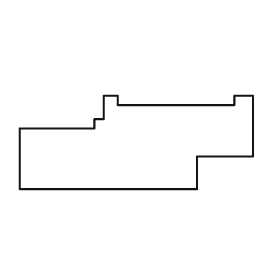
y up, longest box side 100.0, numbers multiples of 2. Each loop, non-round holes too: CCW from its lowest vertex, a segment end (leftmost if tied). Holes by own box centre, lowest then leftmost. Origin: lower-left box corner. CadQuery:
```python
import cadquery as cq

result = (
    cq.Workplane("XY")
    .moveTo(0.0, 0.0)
    .lineTo(76.0, 0.0)
    .lineTo(76.0, 14.0)
    .lineTo(100.0, 14.0)
    .lineTo(100.0, 40.0)
    .lineTo(92.0, 40.0)
    .lineTo(92.0, 36.0)
    .lineTo(42.0, 36.0)
    .lineTo(42.0, 40.0)
    .lineTo(36.0, 40.0)
    .lineTo(36.0, 30.0)
    .lineTo(32.0, 30.0)
    .lineTo(32.0, 26.0)
    .lineTo(0.0, 26.0)
    .close()
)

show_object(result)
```